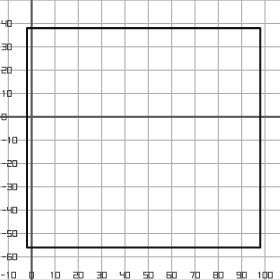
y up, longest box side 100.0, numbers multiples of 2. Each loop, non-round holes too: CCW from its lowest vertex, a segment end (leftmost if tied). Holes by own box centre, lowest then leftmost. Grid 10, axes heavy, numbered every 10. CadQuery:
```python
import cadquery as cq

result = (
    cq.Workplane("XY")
    .moveTo(-2.0, -56.0)
    .lineTo(98.0, -56.0)
    .lineTo(98.0, 38.0)
    .lineTo(-2.0, 38.0)
    .close()
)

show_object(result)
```